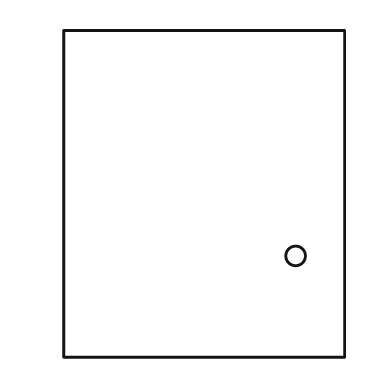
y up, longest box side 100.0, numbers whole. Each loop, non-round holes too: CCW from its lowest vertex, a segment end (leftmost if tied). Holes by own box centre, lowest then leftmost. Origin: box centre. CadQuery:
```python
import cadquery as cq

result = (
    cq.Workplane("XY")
    .moveTo(-43.0, -50.0)
    .lineTo(43.0, -50.0)
    .lineTo(43.0, 50.0)
    .lineTo(-43.0, 50.0)
    .close()
    .moveTo(28.0, -19.0)
    .circle(3.0)
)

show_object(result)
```